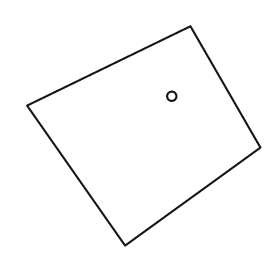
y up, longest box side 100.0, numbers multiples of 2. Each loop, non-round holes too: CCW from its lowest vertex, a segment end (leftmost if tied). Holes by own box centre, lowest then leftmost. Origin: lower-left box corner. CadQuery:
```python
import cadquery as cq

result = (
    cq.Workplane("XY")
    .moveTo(42.0, 0.0)
    .lineTo(100.0, 42.0)
    .lineTo(70.0, 94.0)
    .lineTo(0.0, 60.0)
    .close()
    .moveTo(62.0, 64.0)
    .circle(2.0)
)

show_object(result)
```